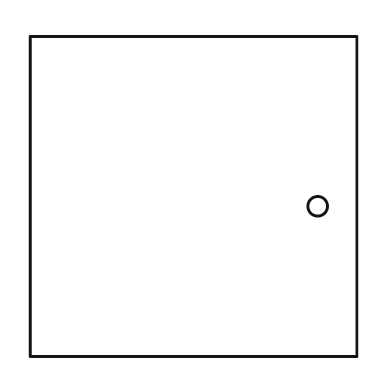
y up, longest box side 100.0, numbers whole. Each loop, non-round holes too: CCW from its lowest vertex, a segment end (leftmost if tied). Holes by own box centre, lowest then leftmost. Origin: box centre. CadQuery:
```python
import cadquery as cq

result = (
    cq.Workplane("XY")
    .moveTo(-50.0, -49.0)
    .lineTo(50.0, -49.0)
    .lineTo(50.0, 49.0)
    .lineTo(-50.0, 49.0)
    .close()
    .moveTo(38.0, -3.0)
    .circle(3.0)
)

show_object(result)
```